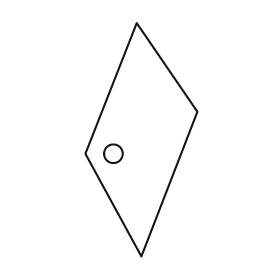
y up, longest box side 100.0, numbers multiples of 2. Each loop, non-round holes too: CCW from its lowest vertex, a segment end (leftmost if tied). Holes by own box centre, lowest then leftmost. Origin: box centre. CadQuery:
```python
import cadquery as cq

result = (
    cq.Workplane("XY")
    .moveTo(0.0, -50.0)
    .lineTo(24.0, 12.0)
    .lineTo(-2.0, 50.0)
    .lineTo(-24.0, -6.0)
    .close()
    .moveTo(-12.0, -6.0)
    .circle(4.0)
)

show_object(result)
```